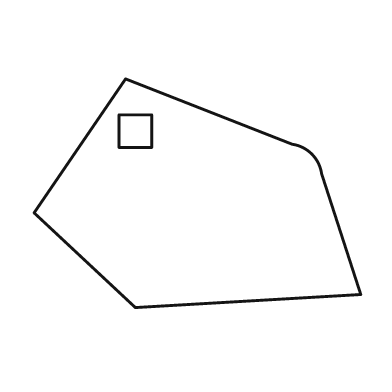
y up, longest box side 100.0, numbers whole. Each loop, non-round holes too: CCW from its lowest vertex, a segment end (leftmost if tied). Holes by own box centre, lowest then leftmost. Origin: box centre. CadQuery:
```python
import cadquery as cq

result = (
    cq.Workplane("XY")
    .moveTo(-19.0, -35.0)
    .lineTo(50.0, -31.0)
    .lineTo(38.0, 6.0)
    .threePointArc((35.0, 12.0), (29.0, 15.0))
    .lineTo(-22.0, 35.0)
    .lineTo(-50.0, -6.0)
    .close()
    .moveTo(-24.0, 14.0)
    .lineTo(-14.0, 14.0)
    .lineTo(-14.0, 24.0)
    .lineTo(-24.0, 24.0)
    .close()
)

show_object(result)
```